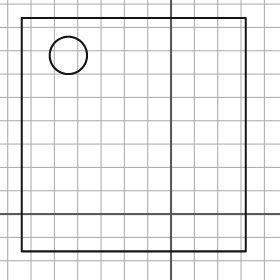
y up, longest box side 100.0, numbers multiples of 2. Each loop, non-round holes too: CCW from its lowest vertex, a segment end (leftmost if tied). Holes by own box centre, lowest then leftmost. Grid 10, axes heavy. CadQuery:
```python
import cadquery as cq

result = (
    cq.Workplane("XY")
    .moveTo(-64.0, -16.0)
    .lineTo(32.0, -16.0)
    .lineTo(32.0, 84.0)
    .lineTo(-64.0, 84.0)
    .close()
    .moveTo(-44.0, 68.0)
    .circle(8.0)
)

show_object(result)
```